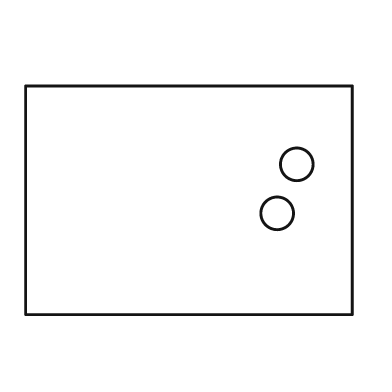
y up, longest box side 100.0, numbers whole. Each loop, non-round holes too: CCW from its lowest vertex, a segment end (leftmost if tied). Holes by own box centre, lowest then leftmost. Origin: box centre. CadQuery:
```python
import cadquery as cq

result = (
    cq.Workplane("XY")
    .moveTo(-50.0, -35.0)
    .lineTo(50.0, -35.0)
    .lineTo(50.0, 35.0)
    .lineTo(-50.0, 35.0)
    .close()
    .moveTo(27.0, -4.0)
    .circle(5.0)
    .moveTo(33.0, 11.0)
    .circle(5.0)
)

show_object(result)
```